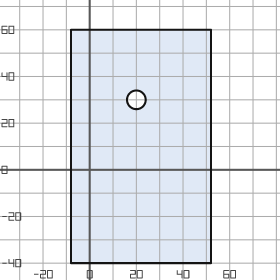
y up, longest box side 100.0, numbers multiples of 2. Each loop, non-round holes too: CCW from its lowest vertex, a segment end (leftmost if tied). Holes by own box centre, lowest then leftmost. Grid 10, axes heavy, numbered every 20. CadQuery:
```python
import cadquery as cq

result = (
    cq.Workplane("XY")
    .moveTo(-8.0, -40.0)
    .lineTo(52.0, -40.0)
    .lineTo(52.0, 60.0)
    .lineTo(-8.0, 60.0)
    .close()
    .moveTo(20.0, 30.0)
    .circle(4.0)
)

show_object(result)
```